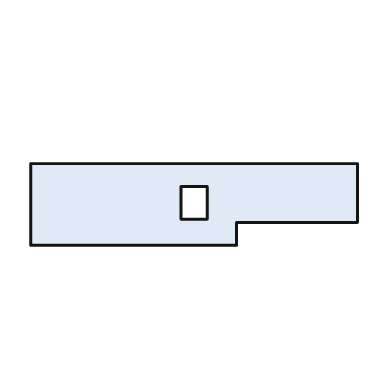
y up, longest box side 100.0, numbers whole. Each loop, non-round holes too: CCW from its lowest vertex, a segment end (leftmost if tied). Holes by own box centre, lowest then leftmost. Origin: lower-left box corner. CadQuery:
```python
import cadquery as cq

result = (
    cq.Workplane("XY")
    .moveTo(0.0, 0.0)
    .lineTo(63.0, 0.0)
    .lineTo(63.0, 7.0)
    .lineTo(100.0, 7.0)
    .lineTo(100.0, 25.0)
    .lineTo(0.0, 25.0)
    .close()
    .moveTo(46.0, 8.0)
    .lineTo(54.0, 8.0)
    .lineTo(54.0, 18.0)
    .lineTo(46.0, 18.0)
    .close()
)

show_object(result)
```